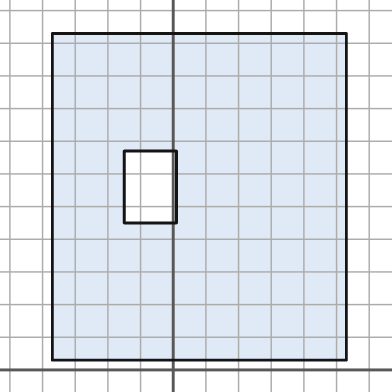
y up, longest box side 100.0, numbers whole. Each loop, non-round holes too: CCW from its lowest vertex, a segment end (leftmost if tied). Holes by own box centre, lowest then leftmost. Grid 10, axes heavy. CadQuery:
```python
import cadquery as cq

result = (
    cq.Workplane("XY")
    .moveTo(-37.0, 3.0)
    .lineTo(53.0, 3.0)
    .lineTo(53.0, 103.0)
    .lineTo(-37.0, 103.0)
    .close()
    .moveTo(-15.0, 45.0)
    .lineTo(1.0, 45.0)
    .lineTo(1.0, 67.0)
    .lineTo(-15.0, 67.0)
    .close()
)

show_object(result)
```